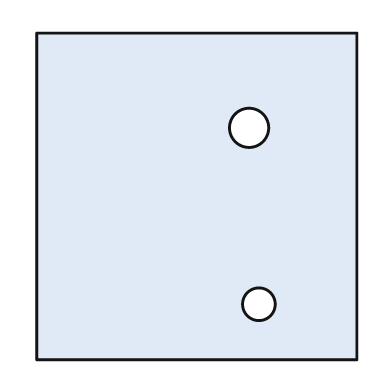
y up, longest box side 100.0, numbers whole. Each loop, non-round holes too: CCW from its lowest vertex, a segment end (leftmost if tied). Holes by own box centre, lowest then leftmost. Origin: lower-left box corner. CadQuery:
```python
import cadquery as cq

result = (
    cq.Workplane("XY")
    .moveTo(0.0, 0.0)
    .lineTo(98.0, 0.0)
    .lineTo(98.0, 100.0)
    .lineTo(0.0, 100.0)
    .close()
    .moveTo(68.0, 17.0)
    .circle(5.0)
    .moveTo(65.0, 71.0)
    .circle(6.0)
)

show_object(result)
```